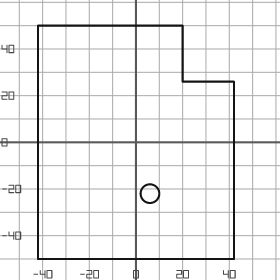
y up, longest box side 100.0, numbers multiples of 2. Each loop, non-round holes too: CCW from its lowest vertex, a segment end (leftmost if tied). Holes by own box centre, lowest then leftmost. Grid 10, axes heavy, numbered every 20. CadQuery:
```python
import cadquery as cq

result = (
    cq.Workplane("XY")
    .moveTo(-42.0, -50.0)
    .lineTo(42.0, -50.0)
    .lineTo(42.0, 26.0)
    .lineTo(20.0, 26.0)
    .lineTo(20.0, 50.0)
    .lineTo(-42.0, 50.0)
    .close()
    .moveTo(6.0, -22.0)
    .circle(4.0)
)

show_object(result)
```